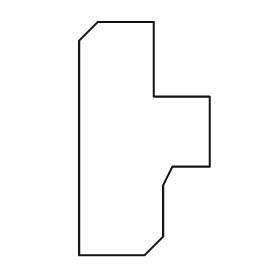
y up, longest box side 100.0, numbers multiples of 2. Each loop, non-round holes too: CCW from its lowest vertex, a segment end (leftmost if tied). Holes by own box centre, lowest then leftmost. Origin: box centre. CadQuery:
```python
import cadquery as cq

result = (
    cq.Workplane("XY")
    .moveTo(-28.0, -50.0)
    .lineTo(0.0, -50.0)
    .lineTo(8.0, -42.0)
    .lineTo(8.0, -20.0)
    .lineTo(12.0, -12.0)
    .lineTo(28.0, -12.0)
    .lineTo(28.0, 18.0)
    .lineTo(4.0, 18.0)
    .lineTo(4.0, 50.0)
    .lineTo(-20.0, 50.0)
    .lineTo(-28.0, 42.0)
    .close()
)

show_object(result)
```